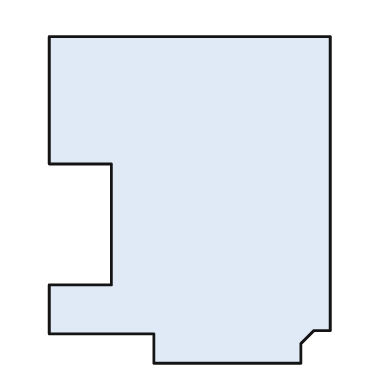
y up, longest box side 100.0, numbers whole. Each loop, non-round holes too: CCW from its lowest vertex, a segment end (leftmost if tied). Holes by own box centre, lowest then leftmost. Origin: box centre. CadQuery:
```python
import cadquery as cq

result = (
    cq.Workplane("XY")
    .moveTo(-11.0, -50.0)
    .lineTo(34.0, -50.0)
    .lineTo(34.0, -44.0)
    .lineTo(38.0, -40.0)
    .lineTo(43.0, -40.0)
    .lineTo(43.0, 50.0)
    .lineTo(-43.0, 50.0)
    .lineTo(-43.0, 11.0)
    .lineTo(-24.0, 11.0)
    .lineTo(-24.0, -26.0)
    .lineTo(-43.0, -26.0)
    .lineTo(-43.0, -41.0)
    .lineTo(-11.0, -41.0)
    .close()
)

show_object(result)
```